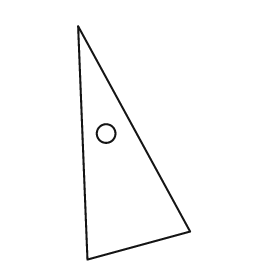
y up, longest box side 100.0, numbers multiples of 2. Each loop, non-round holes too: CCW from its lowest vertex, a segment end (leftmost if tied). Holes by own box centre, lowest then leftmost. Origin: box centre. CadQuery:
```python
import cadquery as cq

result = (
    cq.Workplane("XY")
    .moveTo(-20.0, -50.0)
    .lineTo(24.0, -38.0)
    .lineTo(-24.0, 50.0)
    .close()
    .moveTo(-12.0, 4.0)
    .circle(4.0)
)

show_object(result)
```